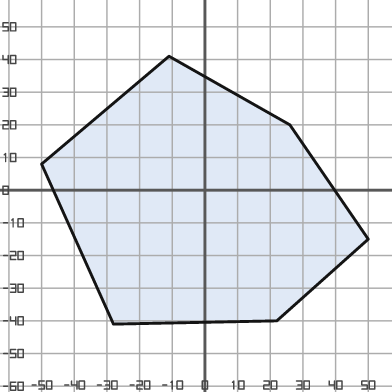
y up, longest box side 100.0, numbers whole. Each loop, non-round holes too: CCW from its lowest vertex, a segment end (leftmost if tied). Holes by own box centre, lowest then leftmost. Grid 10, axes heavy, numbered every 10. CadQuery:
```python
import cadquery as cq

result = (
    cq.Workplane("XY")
    .moveTo(-28.0, -41.0)
    .lineTo(22.0, -40.0)
    .lineTo(50.0, -15.0)
    .lineTo(26.0, 20.0)
    .lineTo(-11.0, 41.0)
    .lineTo(-50.0, 8.0)
    .close()
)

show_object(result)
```